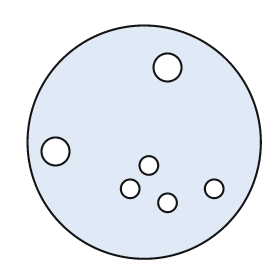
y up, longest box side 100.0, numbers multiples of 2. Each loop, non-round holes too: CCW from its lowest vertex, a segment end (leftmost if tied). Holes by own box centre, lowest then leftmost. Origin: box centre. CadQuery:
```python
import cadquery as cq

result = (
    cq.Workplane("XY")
    .moveTo(0.0, 0.0)
    .circle(50.0)
    .moveTo(10.0, -26.0)
    .circle(4.0)
    .moveTo(-6.0, -20.0)
    .circle(4.0)
    .moveTo(30.0, -20.0)
    .circle(4.0)
    .moveTo(2.0, -10.0)
    .circle(4.0)
    .moveTo(-38.0, -4.0)
    .circle(6.0)
    .moveTo(10.0, 32.0)
    .circle(6.0)
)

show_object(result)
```